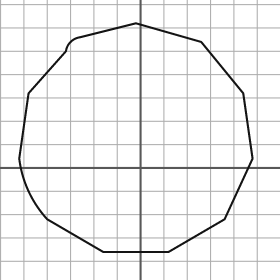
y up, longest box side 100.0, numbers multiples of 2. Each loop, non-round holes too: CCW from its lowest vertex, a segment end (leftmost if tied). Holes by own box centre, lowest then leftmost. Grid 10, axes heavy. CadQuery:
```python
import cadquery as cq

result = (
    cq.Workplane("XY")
    .moveTo(-16.0, -36.0)
    .lineTo(12.0, -36.0)
    .lineTo(36.0, -22.0)
    .lineTo(48.0, 4.0)
    .lineTo(44.0, 32.0)
    .lineTo(26.0, 54.0)
    .lineTo(-2.0, 62.0)
    .lineTo(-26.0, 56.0)
    .threePointArc((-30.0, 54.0), (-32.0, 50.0))
    .lineTo(-48.0, 32.0)
    .lineTo(-52.0, 4.0)
    .threePointArc((-48.0, -10.0), (-40.0, -22.0))
    .close()
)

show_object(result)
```